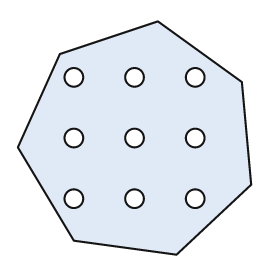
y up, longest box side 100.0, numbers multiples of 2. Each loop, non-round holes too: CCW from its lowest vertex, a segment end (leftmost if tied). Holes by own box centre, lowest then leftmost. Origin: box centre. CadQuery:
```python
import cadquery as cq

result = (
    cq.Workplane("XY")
    .moveTo(18.0, -50.0)
    .lineTo(50.0, -20.0)
    .lineTo(46.0, 24.0)
    .lineTo(10.0, 50.0)
    .lineTo(-32.0, 36.0)
    .lineTo(-50.0, -4.0)
    .lineTo(-26.0, -44.0)
    .close()
    .moveTo(-26.0, -26.0)
    .circle(4.0)
    .moveTo(0.0, -26.0)
    .circle(4.0)
    .moveTo(26.0, -26.0)
    .circle(4.0)
    .moveTo(-26.0, 0.0)
    .circle(4.0)
    .moveTo(0.0, 0.0)
    .circle(4.0)
    .moveTo(26.0, 0.0)
    .circle(4.0)
    .moveTo(-26.0, 26.0)
    .circle(4.0)
    .moveTo(0.0, 26.0)
    .circle(4.0)
    .moveTo(26.0, 26.0)
    .circle(4.0)
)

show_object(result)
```